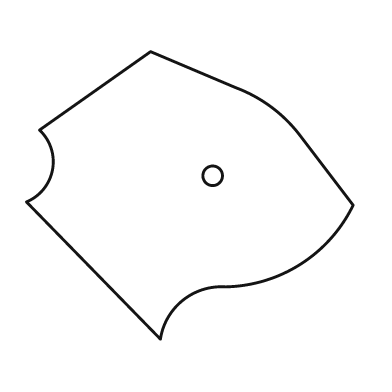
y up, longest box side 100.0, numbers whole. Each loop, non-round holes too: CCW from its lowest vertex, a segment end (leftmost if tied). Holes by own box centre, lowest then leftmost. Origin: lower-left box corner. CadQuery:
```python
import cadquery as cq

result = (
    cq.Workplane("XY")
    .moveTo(41.0, 0.0)
    .threePointArc((48.0, 12.0), (61.0, 16.0))
    .threePointArc((84.0, 23.0), (100.0, 41.0))
    .lineTo(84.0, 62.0)
    .threePointArc((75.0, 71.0), (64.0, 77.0))
    .lineTo(38.0, 88.0)
    .lineTo(4.0, 64.0)
    .threePointArc((8.0, 52.0), (0.0, 42.0))
    .close()
    .moveTo(57.0, 50.0)
    .circle(3.0)
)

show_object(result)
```